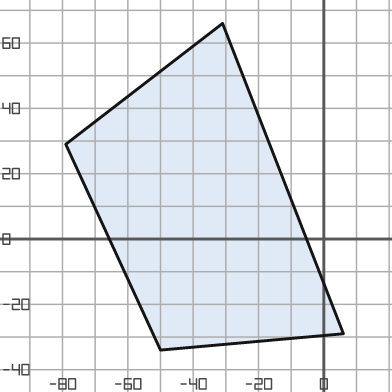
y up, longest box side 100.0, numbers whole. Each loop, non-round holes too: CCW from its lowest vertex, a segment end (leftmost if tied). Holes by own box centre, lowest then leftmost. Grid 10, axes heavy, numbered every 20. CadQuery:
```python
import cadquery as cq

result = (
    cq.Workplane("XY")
    .moveTo(-50.0, -34.0)
    .lineTo(6.0, -29.0)
    .lineTo(-31.0, 66.0)
    .lineTo(-79.0, 29.0)
    .close()
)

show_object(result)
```